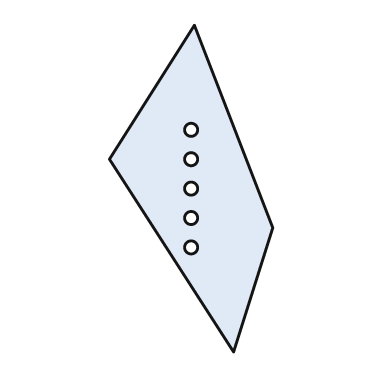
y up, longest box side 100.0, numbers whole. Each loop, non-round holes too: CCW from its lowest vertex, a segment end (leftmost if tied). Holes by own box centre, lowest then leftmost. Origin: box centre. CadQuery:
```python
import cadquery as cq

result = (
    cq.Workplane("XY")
    .moveTo(13.0, -50.0)
    .lineTo(25.0, -12.0)
    .lineTo(1.0, 50.0)
    .lineTo(-25.0, 9.0)
    .close()
    .moveTo(0.0, -18.0)
    .circle(2.0)
    .moveTo(0.0, -9.0)
    .circle(2.0)
    .moveTo(0.0, 0.0)
    .circle(2.0)
    .moveTo(0.0, 9.0)
    .circle(2.0)
    .moveTo(0.0, 18.0)
    .circle(2.0)
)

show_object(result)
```